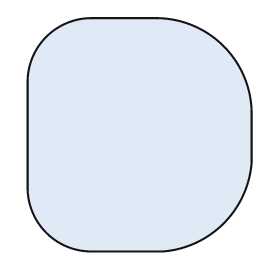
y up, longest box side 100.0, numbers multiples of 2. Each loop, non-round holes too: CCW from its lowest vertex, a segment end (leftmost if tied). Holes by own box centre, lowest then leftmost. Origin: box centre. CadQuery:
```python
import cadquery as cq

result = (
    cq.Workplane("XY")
    .moveTo(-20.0, -50.0)
    .lineTo(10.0, -50.0)
    .threePointArc((36.0, -38.0), (48.0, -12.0))
    .lineTo(48.0, 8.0)
    .threePointArc((36.0, 38.0), (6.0, 50.0))
    .lineTo(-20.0, 50.0)
    .threePointArc((-40.0, 42.0), (-48.0, 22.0))
    .lineTo(-48.0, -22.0)
    .threePointArc((-40.0, -42.0), (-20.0, -50.0))
    .close()
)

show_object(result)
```